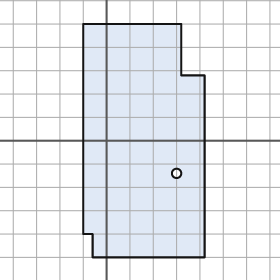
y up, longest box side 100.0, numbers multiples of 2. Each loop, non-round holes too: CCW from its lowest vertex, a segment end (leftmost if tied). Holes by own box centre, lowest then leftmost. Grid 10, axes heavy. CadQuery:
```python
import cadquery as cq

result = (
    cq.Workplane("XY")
    .moveTo(-6.0, -50.0)
    .lineTo(42.0, -50.0)
    .lineTo(42.0, 28.0)
    .lineTo(32.0, 28.0)
    .lineTo(32.0, 50.0)
    .lineTo(-10.0, 50.0)
    .lineTo(-10.0, -40.0)
    .lineTo(-6.0, -40.0)
    .close()
    .moveTo(30.0, -14.0)
    .circle(2.0)
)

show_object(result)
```